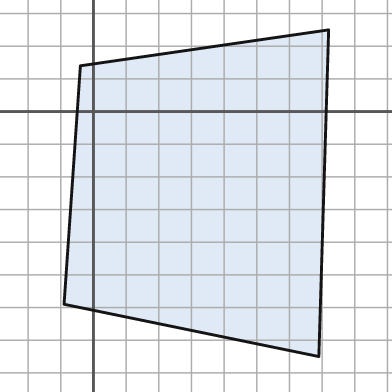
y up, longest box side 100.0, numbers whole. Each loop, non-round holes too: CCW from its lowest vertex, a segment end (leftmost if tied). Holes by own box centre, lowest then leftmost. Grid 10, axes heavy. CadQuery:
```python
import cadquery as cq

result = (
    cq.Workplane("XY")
    .moveTo(69.0, -75.0)
    .lineTo(72.0, 25.0)
    .lineTo(-4.0, 14.0)
    .lineTo(-9.0, -59.0)
    .close()
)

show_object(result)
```